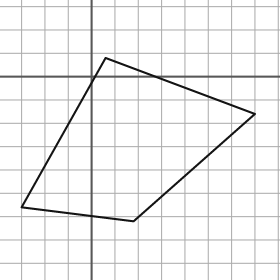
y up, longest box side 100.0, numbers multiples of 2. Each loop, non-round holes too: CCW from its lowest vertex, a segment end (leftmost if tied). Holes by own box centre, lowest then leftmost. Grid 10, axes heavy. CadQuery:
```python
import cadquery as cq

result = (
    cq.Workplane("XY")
    .moveTo(18.0, -62.0)
    .lineTo(70.0, -16.0)
    .lineTo(6.0, 8.0)
    .lineTo(-30.0, -56.0)
    .close()
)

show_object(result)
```